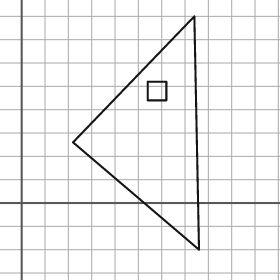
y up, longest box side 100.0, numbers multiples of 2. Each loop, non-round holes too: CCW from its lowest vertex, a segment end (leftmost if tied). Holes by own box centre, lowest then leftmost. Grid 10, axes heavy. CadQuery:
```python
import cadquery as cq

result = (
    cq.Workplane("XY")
    .moveTo(76.0, -20.0)
    .lineTo(74.0, 80.0)
    .lineTo(22.0, 26.0)
    .close()
    .moveTo(54.0, 44.0)
    .lineTo(62.0, 44.0)
    .lineTo(62.0, 52.0)
    .lineTo(54.0, 52.0)
    .close()
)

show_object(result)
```